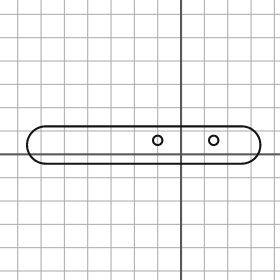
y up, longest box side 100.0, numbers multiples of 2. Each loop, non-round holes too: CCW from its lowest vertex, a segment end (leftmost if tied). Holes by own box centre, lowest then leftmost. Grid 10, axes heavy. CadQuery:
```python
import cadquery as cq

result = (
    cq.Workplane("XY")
    .moveTo(-58.0, -4.0)
    .lineTo(26.0, -4.0)
    .threePointArc((34.0, 4.0), (26.0, 12.0))
    .lineTo(-58.0, 12.0)
    .threePointArc((-66.0, 4.0), (-58.0, -4.0))
    .close()
    .moveTo(-10.0, 6.0)
    .circle(2.0)
    .moveTo(14.0, 6.0)
    .circle(2.0)
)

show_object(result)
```